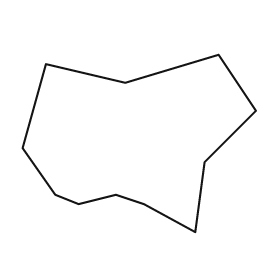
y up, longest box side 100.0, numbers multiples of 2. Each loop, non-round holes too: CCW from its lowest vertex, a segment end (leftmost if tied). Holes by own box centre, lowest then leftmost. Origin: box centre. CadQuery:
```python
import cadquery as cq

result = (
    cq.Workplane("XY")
    .moveTo(24.0, -38.0)
    .lineTo(28.0, -8.0)
    .lineTo(50.0, 14.0)
    .lineTo(34.0, 38.0)
    .lineTo(-6.0, 26.0)
    .lineTo(-40.0, 34.0)
    .lineTo(-50.0, -2.0)
    .lineTo(-36.0, -22.0)
    .lineTo(-26.0, -26.0)
    .lineTo(-10.0, -22.0)
    .lineTo(2.0, -26.0)
    .close()
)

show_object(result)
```